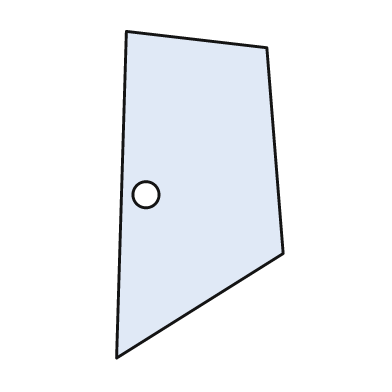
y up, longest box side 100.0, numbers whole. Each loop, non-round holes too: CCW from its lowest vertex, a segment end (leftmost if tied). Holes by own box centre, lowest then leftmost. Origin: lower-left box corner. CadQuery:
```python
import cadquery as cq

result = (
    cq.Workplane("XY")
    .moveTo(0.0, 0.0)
    .lineTo(51.0, 32.0)
    .lineTo(46.0, 95.0)
    .lineTo(3.0, 100.0)
    .close()
    .moveTo(9.0, 50.0)
    .circle(4.0)
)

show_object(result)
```